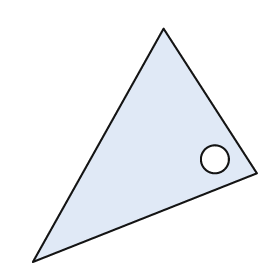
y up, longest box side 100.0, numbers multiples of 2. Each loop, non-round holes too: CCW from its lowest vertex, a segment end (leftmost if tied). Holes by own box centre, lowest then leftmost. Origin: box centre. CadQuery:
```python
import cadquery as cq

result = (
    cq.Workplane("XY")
    .moveTo(-48.0, -50.0)
    .lineTo(48.0, -12.0)
    .lineTo(8.0, 50.0)
    .close()
    .moveTo(30.0, -6.0)
    .circle(6.0)
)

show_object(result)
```